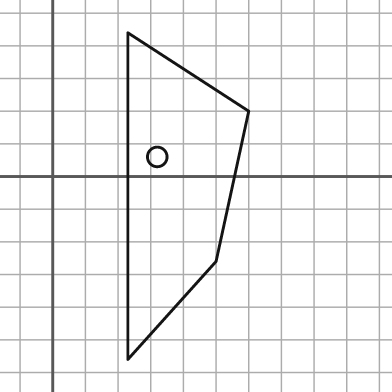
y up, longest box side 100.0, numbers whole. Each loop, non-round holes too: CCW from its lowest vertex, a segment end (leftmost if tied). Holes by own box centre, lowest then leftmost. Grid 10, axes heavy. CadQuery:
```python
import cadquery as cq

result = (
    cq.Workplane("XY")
    .moveTo(23.0, -56.0)
    .lineTo(50.0, -26.0)
    .lineTo(60.0, 20.0)
    .lineTo(23.0, 44.0)
    .close()
    .moveTo(32.0, 6.0)
    .circle(3.0)
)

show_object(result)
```